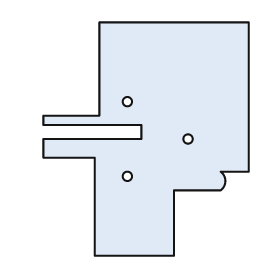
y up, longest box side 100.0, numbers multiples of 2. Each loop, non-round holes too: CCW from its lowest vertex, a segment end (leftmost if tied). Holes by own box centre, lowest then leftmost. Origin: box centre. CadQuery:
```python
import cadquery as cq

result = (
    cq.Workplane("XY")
    .moveTo(-22.0, -50.0)
    .lineTo(12.0, -50.0)
    .lineTo(12.0, -22.0)
    .lineTo(32.0, -22.0)
    .threePointArc((34.0, -18.0), (32.0, -14.0))
    .lineTo(44.0, -14.0)
    .lineTo(44.0, 50.0)
    .lineTo(-20.0, 50.0)
    .lineTo(-20.0, 10.0)
    .lineTo(-44.0, 10.0)
    .lineTo(-44.0, 6.0)
    .lineTo(-2.0, 6.0)
    .lineTo(-2.0, 0.0)
    .lineTo(-44.0, 0.0)
    .lineTo(-44.0, -8.0)
    .lineTo(-22.0, -8.0)
    .close()
    .moveTo(-8.0, -16.0)
    .circle(2.0)
    .moveTo(18.0, 0.0)
    .circle(2.0)
    .moveTo(-8.0, 16.0)
    .circle(2.0)
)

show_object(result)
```